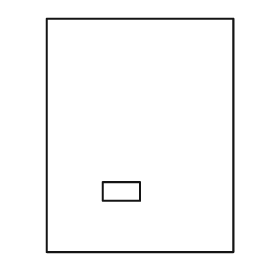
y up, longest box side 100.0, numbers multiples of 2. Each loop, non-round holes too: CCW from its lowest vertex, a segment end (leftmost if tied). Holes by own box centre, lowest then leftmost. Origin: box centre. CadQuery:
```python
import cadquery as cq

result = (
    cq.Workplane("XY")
    .moveTo(-40.0, -50.0)
    .lineTo(40.0, -50.0)
    .lineTo(40.0, 50.0)
    .lineTo(-40.0, 50.0)
    .close()
    .moveTo(-16.0, -28.0)
    .lineTo(0.0, -28.0)
    .lineTo(0.0, -20.0)
    .lineTo(-16.0, -20.0)
    .close()
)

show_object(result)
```